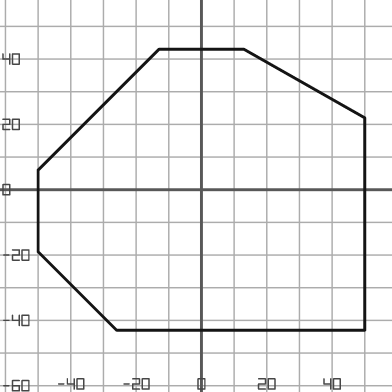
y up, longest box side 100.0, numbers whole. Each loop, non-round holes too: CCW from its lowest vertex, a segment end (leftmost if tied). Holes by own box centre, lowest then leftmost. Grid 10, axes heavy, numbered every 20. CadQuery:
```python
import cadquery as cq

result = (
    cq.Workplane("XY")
    .moveTo(-26.0, -43.0)
    .lineTo(50.0, -43.0)
    .lineTo(50.0, 22.0)
    .lineTo(13.0, 43.0)
    .lineTo(-13.0, 43.0)
    .lineTo(-50.0, 6.0)
    .lineTo(-50.0, -19.0)
    .close()
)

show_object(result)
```